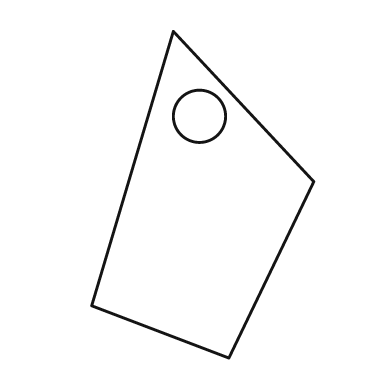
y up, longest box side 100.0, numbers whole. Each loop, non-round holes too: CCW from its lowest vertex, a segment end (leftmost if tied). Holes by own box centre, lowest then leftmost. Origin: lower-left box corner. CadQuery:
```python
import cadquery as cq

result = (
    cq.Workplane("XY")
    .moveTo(42.0, 0.0)
    .lineTo(68.0, 54.0)
    .lineTo(25.0, 100.0)
    .lineTo(0.0, 16.0)
    .close()
    .moveTo(33.0, 74.0)
    .circle(8.0)
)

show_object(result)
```